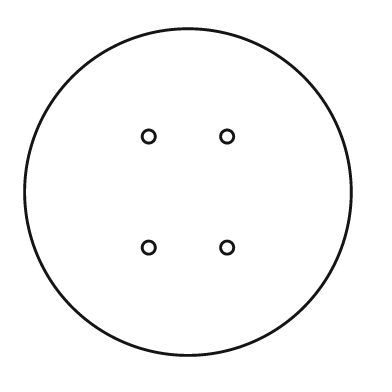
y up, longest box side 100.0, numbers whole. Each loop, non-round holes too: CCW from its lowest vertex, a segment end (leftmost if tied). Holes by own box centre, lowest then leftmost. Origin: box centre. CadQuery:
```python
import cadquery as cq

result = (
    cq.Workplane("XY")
    .moveTo(0.0, 0.0)
    .circle(50.0)
    .moveTo(-12.0, -17.0)
    .circle(2.0)
    .moveTo(12.0, -17.0)
    .circle(2.0)
    .moveTo(-12.0, 17.0)
    .circle(2.0)
    .moveTo(12.0, 17.0)
    .circle(2.0)
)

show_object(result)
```